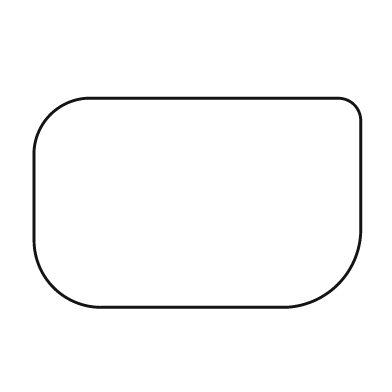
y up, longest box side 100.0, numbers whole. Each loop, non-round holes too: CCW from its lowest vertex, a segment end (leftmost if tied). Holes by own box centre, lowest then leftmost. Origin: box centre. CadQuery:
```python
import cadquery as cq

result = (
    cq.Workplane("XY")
    .moveTo(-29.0, -32.0)
    .lineTo(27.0, -32.0)
    .threePointArc((43.0, -25.0), (50.0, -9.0))
    .lineTo(50.0, 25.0)
    .threePointArc((48.0, 30.0), (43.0, 32.0))
    .lineTo(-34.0, 32.0)
    .threePointArc((-45.0, 27.0), (-50.0, 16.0))
    .lineTo(-50.0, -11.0)
    .threePointArc((-44.0, -26.0), (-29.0, -32.0))
    .close()
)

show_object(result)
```